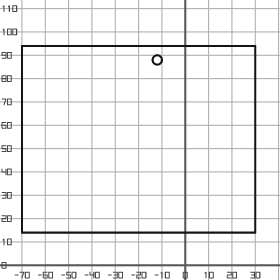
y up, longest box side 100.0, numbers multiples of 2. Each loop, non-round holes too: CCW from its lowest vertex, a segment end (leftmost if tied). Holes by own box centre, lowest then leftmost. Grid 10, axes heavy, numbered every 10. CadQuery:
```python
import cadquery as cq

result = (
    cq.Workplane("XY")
    .moveTo(-70.0, 14.0)
    .lineTo(30.0, 14.0)
    .lineTo(30.0, 94.0)
    .lineTo(-70.0, 94.0)
    .close()
    .moveTo(-12.0, 88.0)
    .circle(2.0)
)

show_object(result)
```